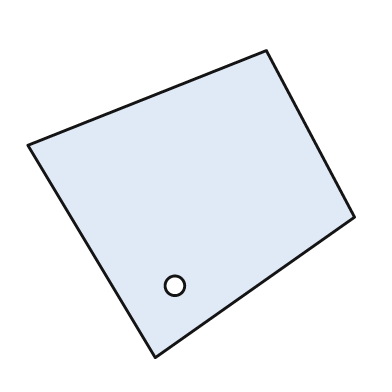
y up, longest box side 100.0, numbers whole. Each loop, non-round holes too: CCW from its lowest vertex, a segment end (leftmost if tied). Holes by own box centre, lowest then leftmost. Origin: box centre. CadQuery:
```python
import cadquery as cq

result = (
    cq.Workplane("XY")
    .moveTo(-11.0, -47.0)
    .lineTo(50.0, -4.0)
    .lineTo(23.0, 47.0)
    .lineTo(-50.0, 18.0)
    .close()
    .moveTo(-5.0, -25.0)
    .circle(3.0)
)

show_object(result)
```